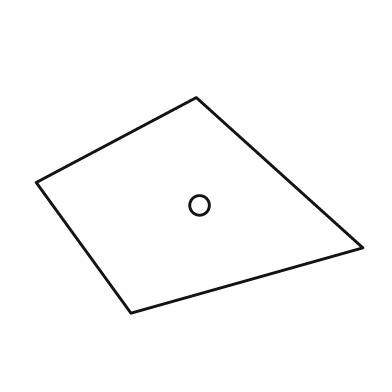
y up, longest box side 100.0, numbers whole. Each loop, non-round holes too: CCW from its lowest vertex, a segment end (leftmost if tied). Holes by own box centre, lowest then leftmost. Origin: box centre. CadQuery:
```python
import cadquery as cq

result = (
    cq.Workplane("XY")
    .moveTo(-21.0, -33.0)
    .lineTo(50.0, -13.0)
    .lineTo(-1.0, 33.0)
    .lineTo(-50.0, 7.0)
    .close()
    .moveTo(0.0, 0.0)
    .circle(3.0)
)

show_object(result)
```